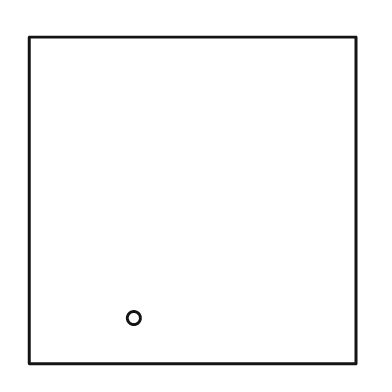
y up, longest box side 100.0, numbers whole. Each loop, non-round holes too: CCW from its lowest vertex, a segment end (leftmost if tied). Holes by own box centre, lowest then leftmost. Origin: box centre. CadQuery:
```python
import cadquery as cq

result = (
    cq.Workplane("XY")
    .moveTo(-50.0, -50.0)
    .lineTo(50.0, -50.0)
    .lineTo(50.0, 50.0)
    .lineTo(-50.0, 50.0)
    .close()
    .moveTo(-18.0, -36.0)
    .circle(2.0)
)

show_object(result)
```